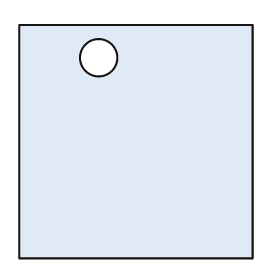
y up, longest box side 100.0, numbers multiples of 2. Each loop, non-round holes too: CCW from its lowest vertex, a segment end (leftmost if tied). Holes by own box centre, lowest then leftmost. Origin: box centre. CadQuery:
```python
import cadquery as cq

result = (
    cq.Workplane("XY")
    .moveTo(-50.0, -50.0)
    .lineTo(50.0, -50.0)
    .lineTo(50.0, 50.0)
    .lineTo(-50.0, 50.0)
    .close()
    .moveTo(-16.0, 36.0)
    .circle(8.0)
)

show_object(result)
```